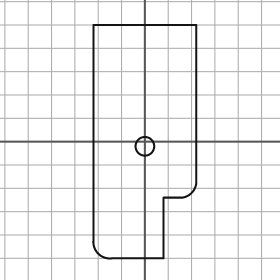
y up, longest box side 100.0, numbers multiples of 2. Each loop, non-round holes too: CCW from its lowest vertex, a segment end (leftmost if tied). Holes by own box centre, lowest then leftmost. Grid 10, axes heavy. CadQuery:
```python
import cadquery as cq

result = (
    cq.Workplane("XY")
    .moveTo(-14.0, -50.0)
    .lineTo(8.0, -50.0)
    .lineTo(8.0, -24.0)
    .lineTo(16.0, -24.0)
    .threePointArc((20.0, -22.0), (22.0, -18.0))
    .lineTo(22.0, 50.0)
    .lineTo(-22.0, 50.0)
    .lineTo(-22.0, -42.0)
    .threePointArc((-20.0, -48.0), (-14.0, -50.0))
    .close()
    .moveTo(0.0, -2.0)
    .circle(4.0)
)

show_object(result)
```